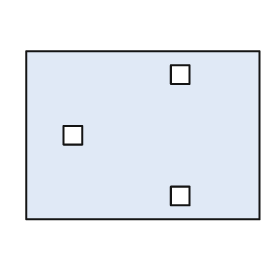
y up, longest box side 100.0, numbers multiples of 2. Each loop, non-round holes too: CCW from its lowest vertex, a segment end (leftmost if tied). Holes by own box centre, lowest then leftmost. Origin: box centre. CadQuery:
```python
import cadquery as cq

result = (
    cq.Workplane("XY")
    .moveTo(-50.0, -36.0)
    .lineTo(50.0, -36.0)
    .lineTo(50.0, 36.0)
    .lineTo(-50.0, 36.0)
    .close()
    .moveTo(12.0, -30.0)
    .lineTo(20.0, -30.0)
    .lineTo(20.0, -22.0)
    .lineTo(12.0, -22.0)
    .close()
    .moveTo(-34.0, -4.0)
    .lineTo(-26.0, -4.0)
    .lineTo(-26.0, 4.0)
    .lineTo(-34.0, 4.0)
    .close()
    .moveTo(12.0, 22.0)
    .lineTo(20.0, 22.0)
    .lineTo(20.0, 30.0)
    .lineTo(12.0, 30.0)
    .close()
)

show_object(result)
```